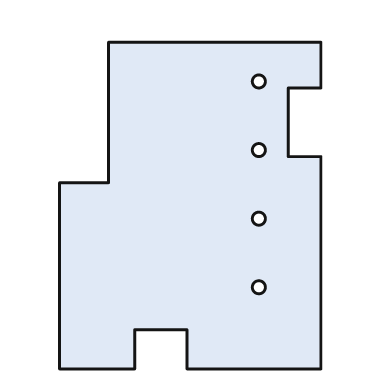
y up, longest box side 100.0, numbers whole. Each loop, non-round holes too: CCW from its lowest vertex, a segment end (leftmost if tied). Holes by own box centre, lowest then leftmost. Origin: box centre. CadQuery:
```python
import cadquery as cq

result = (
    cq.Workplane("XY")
    .moveTo(-40.0, -50.0)
    .lineTo(-17.0, -50.0)
    .lineTo(-17.0, -38.0)
    .lineTo(-1.0, -38.0)
    .lineTo(-1.0, -50.0)
    .lineTo(40.0, -50.0)
    .lineTo(40.0, 15.0)
    .lineTo(30.0, 15.0)
    .lineTo(30.0, 36.0)
    .lineTo(40.0, 36.0)
    .lineTo(40.0, 50.0)
    .lineTo(-25.0, 50.0)
    .lineTo(-25.0, 7.0)
    .lineTo(-40.0, 7.0)
    .close()
    .moveTo(21.0, -25.0)
    .circle(2.0)
    .moveTo(21.0, -4.0)
    .circle(2.0)
    .moveTo(21.0, 17.0)
    .circle(2.0)
    .moveTo(21.0, 38.0)
    .circle(2.0)
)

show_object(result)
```